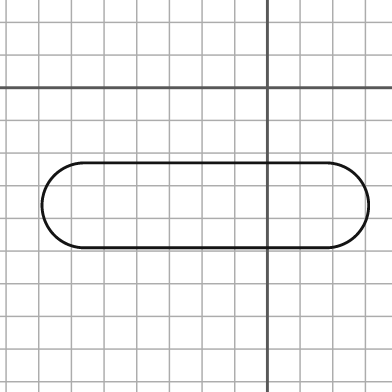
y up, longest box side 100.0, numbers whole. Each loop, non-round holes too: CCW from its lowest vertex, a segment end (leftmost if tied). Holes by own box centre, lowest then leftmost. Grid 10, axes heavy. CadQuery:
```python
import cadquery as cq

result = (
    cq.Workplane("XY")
    .moveTo(-56.0, -49.0)
    .lineTo(18.0, -49.0)
    .threePointArc((31.0, -36.0), (18.0, -23.0))
    .lineTo(-56.0, -23.0)
    .threePointArc((-69.0, -36.0), (-56.0, -49.0))
    .close()
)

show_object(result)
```